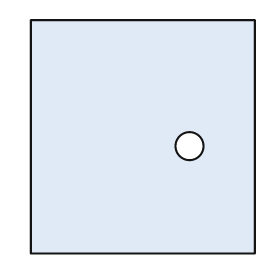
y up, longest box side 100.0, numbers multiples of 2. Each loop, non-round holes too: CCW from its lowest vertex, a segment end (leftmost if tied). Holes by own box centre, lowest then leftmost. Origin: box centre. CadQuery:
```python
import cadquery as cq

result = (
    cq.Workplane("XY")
    .moveTo(-48.0, -50.0)
    .lineTo(48.0, -50.0)
    .lineTo(48.0, 50.0)
    .lineTo(-48.0, 50.0)
    .close()
    .moveTo(20.0, -4.0)
    .circle(6.0)
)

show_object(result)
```